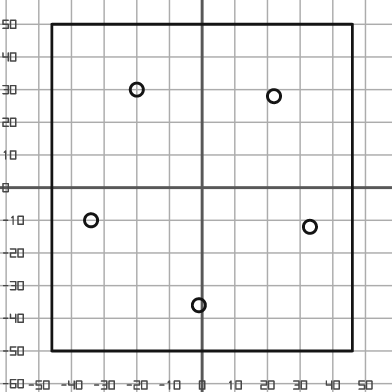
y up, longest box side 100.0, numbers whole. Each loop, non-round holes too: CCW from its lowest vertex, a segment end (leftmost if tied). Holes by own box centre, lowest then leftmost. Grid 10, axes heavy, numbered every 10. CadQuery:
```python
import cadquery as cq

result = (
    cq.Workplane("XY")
    .moveTo(-46.0, -50.0)
    .lineTo(46.0, -50.0)
    .lineTo(46.0, 50.0)
    .lineTo(-46.0, 50.0)
    .close()
    .moveTo(-1.0, -36.0)
    .circle(2.0)
    .moveTo(33.0, -12.0)
    .circle(2.0)
    .moveTo(-34.0, -10.0)
    .circle(2.0)
    .moveTo(22.0, 28.0)
    .circle(2.0)
    .moveTo(-20.0, 30.0)
    .circle(2.0)
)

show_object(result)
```